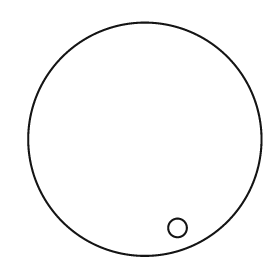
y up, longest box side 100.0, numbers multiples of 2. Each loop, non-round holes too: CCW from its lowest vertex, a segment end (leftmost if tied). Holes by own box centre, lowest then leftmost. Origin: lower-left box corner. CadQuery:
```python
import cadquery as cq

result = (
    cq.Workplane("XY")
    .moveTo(50.0, 50.0)
    .circle(50.0)
    .moveTo(64.0, 12.0)
    .circle(4.0)
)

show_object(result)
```